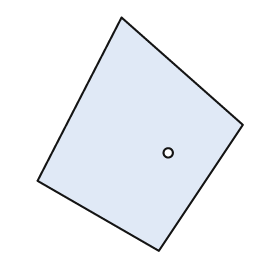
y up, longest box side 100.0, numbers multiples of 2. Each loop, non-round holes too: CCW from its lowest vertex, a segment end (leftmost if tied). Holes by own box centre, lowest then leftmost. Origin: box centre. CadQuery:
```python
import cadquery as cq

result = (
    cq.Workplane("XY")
    .moveTo(8.0, -50.0)
    .lineTo(44.0, 4.0)
    .lineTo(-8.0, 50.0)
    .lineTo(-44.0, -20.0)
    .close()
    .moveTo(12.0, -8.0)
    .circle(2.0)
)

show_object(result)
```